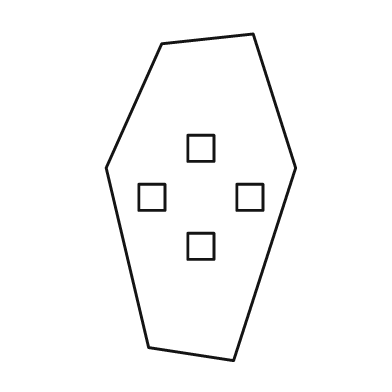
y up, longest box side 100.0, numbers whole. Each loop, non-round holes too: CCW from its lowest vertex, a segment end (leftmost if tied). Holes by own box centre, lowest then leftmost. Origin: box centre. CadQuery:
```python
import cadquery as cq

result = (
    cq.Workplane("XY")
    .moveTo(10.0, -50.0)
    .lineTo(29.0, 9.0)
    .lineTo(16.0, 50.0)
    .lineTo(-12.0, 47.0)
    .lineTo(-29.0, 9.0)
    .lineTo(-16.0, -46.0)
    .close()
    .moveTo(-4.0, -19.0)
    .lineTo(4.0, -19.0)
    .lineTo(4.0, -11.0)
    .lineTo(-4.0, -11.0)
    .close()
    .moveTo(-19.0, -4.0)
    .lineTo(-11.0, -4.0)
    .lineTo(-11.0, 4.0)
    .lineTo(-19.0, 4.0)
    .close()
    .moveTo(11.0, -4.0)
    .lineTo(19.0, -4.0)
    .lineTo(19.0, 4.0)
    .lineTo(11.0, 4.0)
    .close()
    .moveTo(-4.0, 11.0)
    .lineTo(4.0, 11.0)
    .lineTo(4.0, 19.0)
    .lineTo(-4.0, 19.0)
    .close()
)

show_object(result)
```